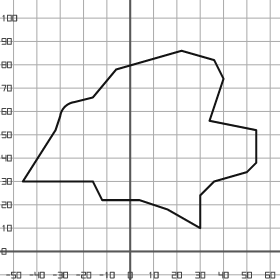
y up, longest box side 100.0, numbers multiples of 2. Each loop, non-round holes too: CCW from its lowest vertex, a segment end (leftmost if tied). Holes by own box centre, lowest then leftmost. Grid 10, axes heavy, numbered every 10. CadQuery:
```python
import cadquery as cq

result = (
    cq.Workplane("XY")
    .moveTo(30.0, 10.0)
    .lineTo(30.0, 24.0)
    .lineTo(36.0, 30.0)
    .lineTo(50.0, 34.0)
    .lineTo(54.0, 38.0)
    .lineTo(54.0, 52.0)
    .lineTo(34.0, 56.0)
    .lineTo(40.0, 74.0)
    .lineTo(36.0, 82.0)
    .lineTo(22.0, 86.0)
    .lineTo(-6.0, 78.0)
    .lineTo(-16.0, 66.0)
    .lineTo(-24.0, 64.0)
    .threePointArc((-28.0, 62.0), (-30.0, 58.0))
    .lineTo(-32.0, 52.0)
    .lineTo(-46.0, 30.0)
    .lineTo(-16.0, 30.0)
    .lineTo(-12.0, 22.0)
    .lineTo(4.0, 22.0)
    .lineTo(16.0, 18.0)
    .close()
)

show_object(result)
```